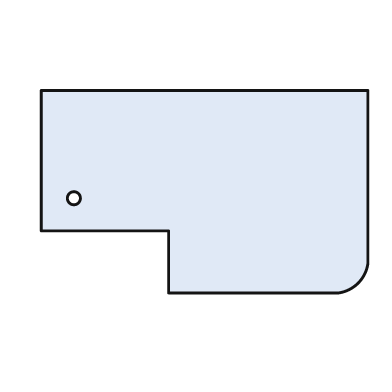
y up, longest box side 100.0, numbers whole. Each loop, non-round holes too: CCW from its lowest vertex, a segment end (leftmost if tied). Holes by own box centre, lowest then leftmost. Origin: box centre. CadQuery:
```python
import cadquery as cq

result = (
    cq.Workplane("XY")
    .moveTo(-11.0, -31.0)
    .lineTo(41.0, -31.0)
    .threePointArc((47.0, -28.0), (50.0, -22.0))
    .lineTo(50.0, 31.0)
    .lineTo(-50.0, 31.0)
    .lineTo(-50.0, -12.0)
    .lineTo(-11.0, -12.0)
    .close()
    .moveTo(-40.0, -2.0)
    .circle(2.0)
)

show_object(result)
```